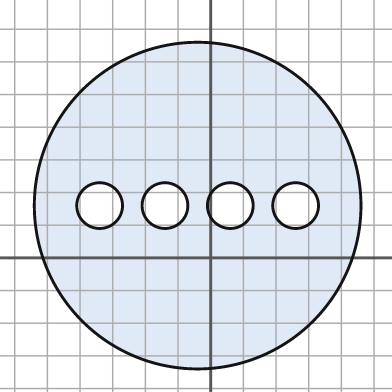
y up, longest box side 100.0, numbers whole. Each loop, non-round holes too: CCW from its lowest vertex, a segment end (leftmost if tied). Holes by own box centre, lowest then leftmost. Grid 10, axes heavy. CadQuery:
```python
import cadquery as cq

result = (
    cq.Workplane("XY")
    .moveTo(-4.0, 16.0)
    .circle(50.0)
    .moveTo(-34.0, 16.0)
    .circle(7.0)
    .moveTo(-14.0, 16.0)
    .circle(7.0)
    .moveTo(6.0, 16.0)
    .circle(7.0)
    .moveTo(26.0, 16.0)
    .circle(7.0)
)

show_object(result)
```